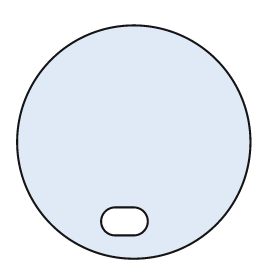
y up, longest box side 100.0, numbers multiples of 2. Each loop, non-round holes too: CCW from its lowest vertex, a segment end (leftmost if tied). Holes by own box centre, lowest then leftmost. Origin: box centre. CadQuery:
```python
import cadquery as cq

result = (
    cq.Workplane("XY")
    .moveTo(0.0, 0.0)
    .circle(50.0)
    .moveTo(-8.0, -40.0)
    .lineTo(0.0, -40.0)
    .threePointArc((6.0, -34.0), (0.0, -28.0))
    .lineTo(-8.0, -28.0)
    .threePointArc((-14.0, -34.0), (-8.0, -40.0))
    .close()
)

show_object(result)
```